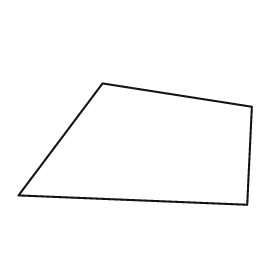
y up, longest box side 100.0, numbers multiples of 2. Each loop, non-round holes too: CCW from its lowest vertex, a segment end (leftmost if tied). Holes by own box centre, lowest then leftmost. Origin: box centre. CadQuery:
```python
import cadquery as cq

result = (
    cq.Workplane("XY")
    .moveTo(48.0, -26.0)
    .lineTo(50.0, 16.0)
    .lineTo(-14.0, 26.0)
    .lineTo(-50.0, -22.0)
    .close()
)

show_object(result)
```